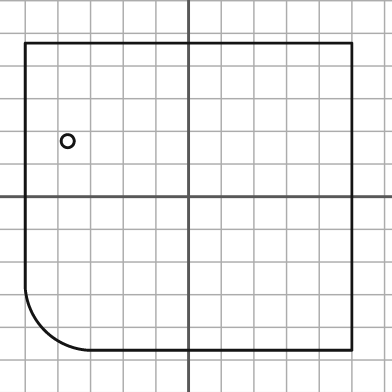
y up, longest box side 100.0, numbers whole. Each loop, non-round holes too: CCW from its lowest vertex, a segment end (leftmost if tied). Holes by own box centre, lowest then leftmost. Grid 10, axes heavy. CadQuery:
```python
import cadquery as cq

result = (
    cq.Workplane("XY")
    .moveTo(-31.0, -47.0)
    .lineTo(50.0, -47.0)
    .lineTo(50.0, 47.0)
    .lineTo(-50.0, 47.0)
    .lineTo(-50.0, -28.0)
    .threePointArc((-44.0, -41.0), (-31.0, -47.0))
    .close()
    .moveTo(-37.0, 17.0)
    .circle(2.0)
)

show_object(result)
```